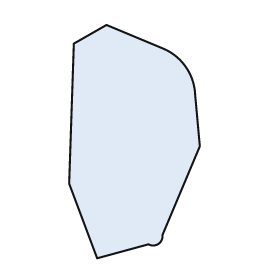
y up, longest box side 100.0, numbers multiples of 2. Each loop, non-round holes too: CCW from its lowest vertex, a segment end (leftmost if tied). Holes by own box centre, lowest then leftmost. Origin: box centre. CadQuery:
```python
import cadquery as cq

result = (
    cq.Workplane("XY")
    .moveTo(-16.0, -50.0)
    .lineTo(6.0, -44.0)
    .threePointArc((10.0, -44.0), (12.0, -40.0))
    .lineTo(28.0, -2.0)
    .lineTo(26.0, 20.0)
    .threePointArc((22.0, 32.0), (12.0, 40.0))
    .lineTo(-12.0, 50.0)
    .lineTo(-26.0, 42.0)
    .lineTo(-28.0, -18.0)
    .close()
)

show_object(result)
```